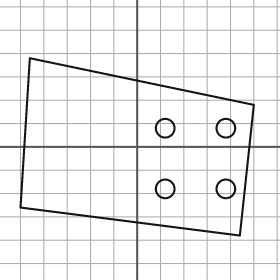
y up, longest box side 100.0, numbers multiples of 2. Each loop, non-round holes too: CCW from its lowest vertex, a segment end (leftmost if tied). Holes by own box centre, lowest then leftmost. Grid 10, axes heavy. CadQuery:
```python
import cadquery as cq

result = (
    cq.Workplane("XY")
    .moveTo(44.0, -38.0)
    .lineTo(50.0, 18.0)
    .lineTo(-46.0, 38.0)
    .lineTo(-50.0, -26.0)
    .close()
    .moveTo(12.0, -18.0)
    .circle(4.0)
    .moveTo(38.0, -18.0)
    .circle(4.0)
    .moveTo(12.0, 8.0)
    .circle(4.0)
    .moveTo(38.0, 8.0)
    .circle(4.0)
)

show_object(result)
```